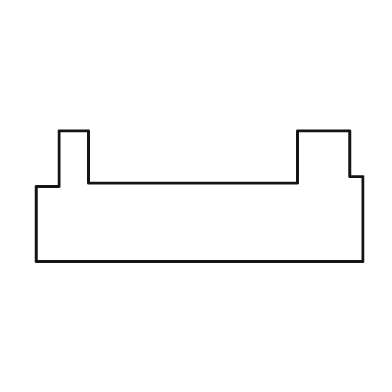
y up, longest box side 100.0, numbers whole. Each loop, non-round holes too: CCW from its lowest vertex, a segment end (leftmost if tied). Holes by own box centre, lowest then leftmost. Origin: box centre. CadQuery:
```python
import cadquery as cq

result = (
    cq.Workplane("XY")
    .moveTo(-50.0, -20.0)
    .lineTo(50.0, -20.0)
    .lineTo(50.0, 6.0)
    .lineTo(46.0, 6.0)
    .lineTo(46.0, 20.0)
    .lineTo(30.0, 20.0)
    .lineTo(30.0, 4.0)
    .lineTo(-34.0, 4.0)
    .lineTo(-34.0, 20.0)
    .lineTo(-43.0, 20.0)
    .lineTo(-43.0, 3.0)
    .lineTo(-50.0, 3.0)
    .close()
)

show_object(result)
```